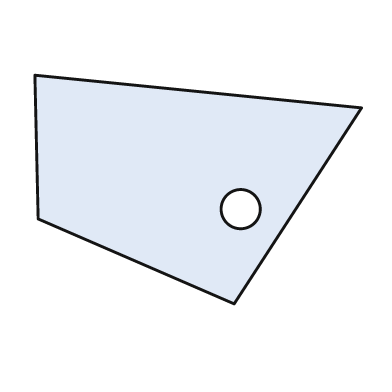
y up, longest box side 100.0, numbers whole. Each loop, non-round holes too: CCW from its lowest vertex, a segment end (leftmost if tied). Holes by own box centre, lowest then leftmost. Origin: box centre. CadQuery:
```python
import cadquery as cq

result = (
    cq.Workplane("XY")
    .moveTo(11.0, -35.0)
    .lineTo(50.0, 25.0)
    .lineTo(-50.0, 35.0)
    .lineTo(-49.0, -9.0)
    .close()
    .moveTo(13.0, -6.0)
    .circle(6.0)
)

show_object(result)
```